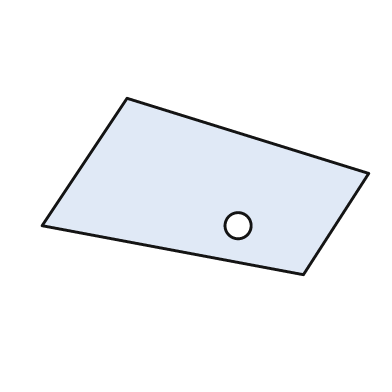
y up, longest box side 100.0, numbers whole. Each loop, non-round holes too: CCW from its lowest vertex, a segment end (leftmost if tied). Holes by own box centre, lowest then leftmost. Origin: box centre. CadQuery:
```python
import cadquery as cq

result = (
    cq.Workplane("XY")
    .moveTo(30.0, -27.0)
    .lineTo(50.0, 4.0)
    .lineTo(-24.0, 27.0)
    .lineTo(-50.0, -12.0)
    .close()
    .moveTo(10.0, -12.0)
    .circle(4.0)
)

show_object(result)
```